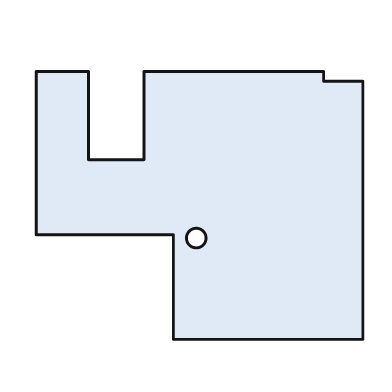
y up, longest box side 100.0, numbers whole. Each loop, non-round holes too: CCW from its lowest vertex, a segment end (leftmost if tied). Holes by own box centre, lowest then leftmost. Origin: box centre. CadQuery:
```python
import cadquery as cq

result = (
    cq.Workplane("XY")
    .moveTo(-8.0, -41.0)
    .lineTo(50.0, -41.0)
    .lineTo(50.0, 38.0)
    .lineTo(38.0, 38.0)
    .lineTo(38.0, 41.0)
    .lineTo(-17.0, 41.0)
    .lineTo(-17.0, 14.0)
    .lineTo(-34.0, 14.0)
    .lineTo(-34.0, 41.0)
    .lineTo(-50.0, 41.0)
    .lineTo(-50.0, -9.0)
    .lineTo(-8.0, -9.0)
    .close()
    .moveTo(-1.0, -10.0)
    .circle(3.0)
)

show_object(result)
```